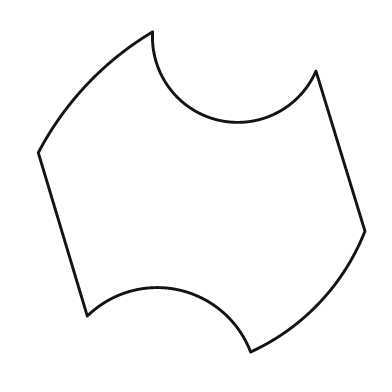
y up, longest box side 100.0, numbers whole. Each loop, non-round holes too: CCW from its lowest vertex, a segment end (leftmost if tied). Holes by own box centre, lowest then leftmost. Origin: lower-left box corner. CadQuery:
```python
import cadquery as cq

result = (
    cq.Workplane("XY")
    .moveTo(65.0, 0.0)
    .threePointArc((86.0, 15.0), (100.0, 37.0))
    .lineTo(85.0, 86.0)
    .threePointArc((55.0, 71.0), (35.0, 98.0))
    .threePointArc((15.0, 82.0), (0.0, 61.0))
    .lineTo(15.0, 11.0)
    .threePointArc((43.0, 19.0), (65.0, 0.0))
    .close()
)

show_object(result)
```